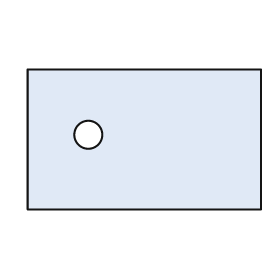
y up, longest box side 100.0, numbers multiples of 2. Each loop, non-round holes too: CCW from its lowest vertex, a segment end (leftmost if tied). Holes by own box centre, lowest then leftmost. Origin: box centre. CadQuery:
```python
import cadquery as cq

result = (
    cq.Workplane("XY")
    .moveTo(-50.0, -30.0)
    .lineTo(50.0, -30.0)
    .lineTo(50.0, 30.0)
    .lineTo(-50.0, 30.0)
    .close()
    .moveTo(-24.0, 2.0)
    .circle(6.0)
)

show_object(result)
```